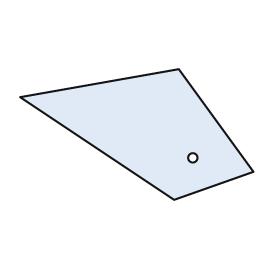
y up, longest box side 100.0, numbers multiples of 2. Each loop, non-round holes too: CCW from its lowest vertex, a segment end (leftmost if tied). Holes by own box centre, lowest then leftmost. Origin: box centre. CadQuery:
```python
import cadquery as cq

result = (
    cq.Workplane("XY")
    .moveTo(16.0, -28.0)
    .lineTo(50.0, -16.0)
    .lineTo(18.0, 28.0)
    .lineTo(-50.0, 16.0)
    .close()
    .moveTo(24.0, -10.0)
    .circle(2.0)
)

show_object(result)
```